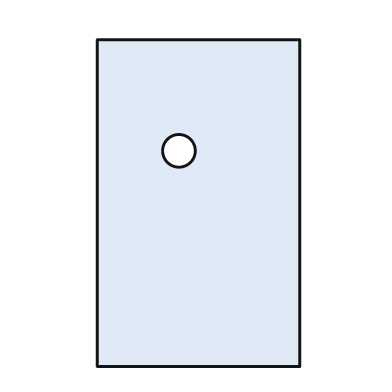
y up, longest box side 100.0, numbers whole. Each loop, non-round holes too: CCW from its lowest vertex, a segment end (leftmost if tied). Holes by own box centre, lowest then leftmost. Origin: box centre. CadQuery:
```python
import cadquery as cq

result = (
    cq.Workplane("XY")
    .moveTo(-31.0, -50.0)
    .lineTo(31.0, -50.0)
    .lineTo(31.0, 50.0)
    .lineTo(-31.0, 50.0)
    .close()
    .moveTo(-6.0, 16.0)
    .circle(5.0)
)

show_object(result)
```